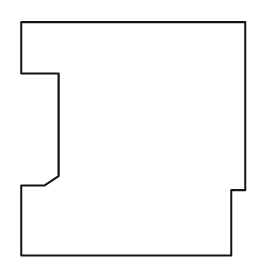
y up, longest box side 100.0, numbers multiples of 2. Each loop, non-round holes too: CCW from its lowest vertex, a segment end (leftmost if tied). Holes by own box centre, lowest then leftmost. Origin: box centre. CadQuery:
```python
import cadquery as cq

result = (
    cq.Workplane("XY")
    .moveTo(-48.0, -50.0)
    .lineTo(42.0, -50.0)
    .lineTo(42.0, -22.0)
    .lineTo(48.0, -22.0)
    .lineTo(48.0, 50.0)
    .lineTo(-48.0, 50.0)
    .lineTo(-48.0, 28.0)
    .lineTo(-32.0, 28.0)
    .lineTo(-32.0, -16.0)
    .lineTo(-38.0, -20.0)
    .lineTo(-48.0, -20.0)
    .close()
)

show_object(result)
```